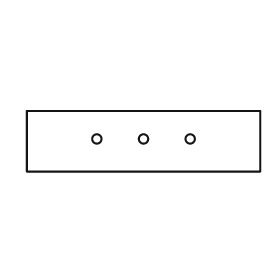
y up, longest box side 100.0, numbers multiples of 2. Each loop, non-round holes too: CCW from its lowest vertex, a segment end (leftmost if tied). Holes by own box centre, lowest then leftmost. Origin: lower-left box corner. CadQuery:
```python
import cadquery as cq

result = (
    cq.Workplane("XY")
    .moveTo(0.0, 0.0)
    .lineTo(100.0, 0.0)
    .lineTo(100.0, 26.0)
    .lineTo(0.0, 26.0)
    .close()
    .moveTo(30.0, 14.0)
    .circle(2.0)
    .moveTo(50.0, 14.0)
    .circle(2.0)
    .moveTo(70.0, 14.0)
    .circle(2.0)
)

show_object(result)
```